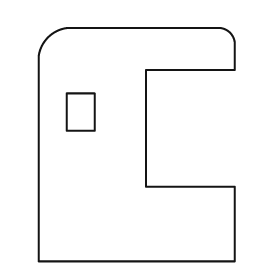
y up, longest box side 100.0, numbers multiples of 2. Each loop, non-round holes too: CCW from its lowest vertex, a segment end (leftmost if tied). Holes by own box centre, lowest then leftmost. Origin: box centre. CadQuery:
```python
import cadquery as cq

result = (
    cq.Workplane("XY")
    .moveTo(-42.0, -50.0)
    .lineTo(42.0, -50.0)
    .lineTo(42.0, -18.0)
    .lineTo(4.0, -18.0)
    .lineTo(4.0, 32.0)
    .lineTo(42.0, 32.0)
    .lineTo(42.0, 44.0)
    .threePointArc((40.0, 48.0), (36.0, 50.0))
    .lineTo(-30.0, 50.0)
    .threePointArc((-38.0, 46.0), (-42.0, 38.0))
    .close()
    .moveTo(-30.0, 6.0)
    .lineTo(-18.0, 6.0)
    .lineTo(-18.0, 22.0)
    .lineTo(-30.0, 22.0)
    .close()
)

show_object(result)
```